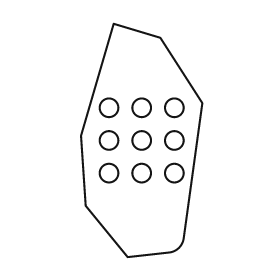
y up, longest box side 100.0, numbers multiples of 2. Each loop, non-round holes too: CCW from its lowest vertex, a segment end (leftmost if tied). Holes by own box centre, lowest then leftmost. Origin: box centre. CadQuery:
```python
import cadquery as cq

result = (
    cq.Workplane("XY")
    .moveTo(-6.0, -50.0)
    .lineTo(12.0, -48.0)
    .threePointArc((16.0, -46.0), (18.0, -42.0))
    .lineTo(26.0, 16.0)
    .lineTo(8.0, 44.0)
    .lineTo(-12.0, 50.0)
    .lineTo(-26.0, 2.0)
    .lineTo(-24.0, -28.0)
    .close()
    .moveTo(-14.0, -14.0)
    .circle(4.0)
    .moveTo(0.0, -14.0)
    .circle(4.0)
    .moveTo(14.0, -14.0)
    .circle(4.0)
    .moveTo(-14.0, 0.0)
    .circle(4.0)
    .moveTo(0.0, 0.0)
    .circle(4.0)
    .moveTo(14.0, 0.0)
    .circle(4.0)
    .moveTo(-14.0, 14.0)
    .circle(4.0)
    .moveTo(0.0, 14.0)
    .circle(4.0)
    .moveTo(14.0, 14.0)
    .circle(4.0)
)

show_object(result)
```